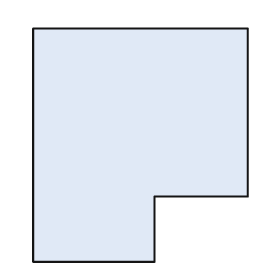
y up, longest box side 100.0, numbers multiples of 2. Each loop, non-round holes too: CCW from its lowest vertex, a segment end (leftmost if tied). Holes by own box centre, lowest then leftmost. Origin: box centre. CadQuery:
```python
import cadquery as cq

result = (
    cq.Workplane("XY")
    .moveTo(-46.0, -50.0)
    .lineTo(6.0, -50.0)
    .lineTo(6.0, -22.0)
    .lineTo(46.0, -22.0)
    .lineTo(46.0, 50.0)
    .lineTo(-46.0, 50.0)
    .close()
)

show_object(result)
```